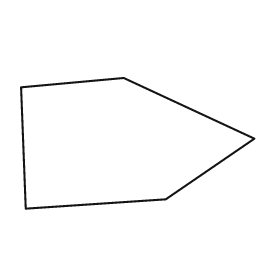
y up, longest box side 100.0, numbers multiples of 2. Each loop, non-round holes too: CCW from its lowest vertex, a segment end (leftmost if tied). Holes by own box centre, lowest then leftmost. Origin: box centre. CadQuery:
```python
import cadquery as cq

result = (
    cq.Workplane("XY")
    .moveTo(-48.0, -28.0)
    .lineTo(12.0, -24.0)
    .lineTo(50.0, 2.0)
    .lineTo(-6.0, 28.0)
    .lineTo(-50.0, 24.0)
    .close()
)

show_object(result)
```